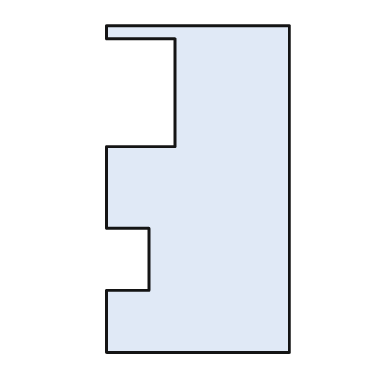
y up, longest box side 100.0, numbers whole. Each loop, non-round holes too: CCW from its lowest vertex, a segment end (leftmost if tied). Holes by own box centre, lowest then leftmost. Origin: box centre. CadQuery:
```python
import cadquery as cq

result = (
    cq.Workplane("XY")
    .moveTo(-28.0, -50.0)
    .lineTo(28.0, -50.0)
    .lineTo(28.0, 50.0)
    .lineTo(-28.0, 50.0)
    .lineTo(-28.0, 46.0)
    .lineTo(-7.0, 46.0)
    .lineTo(-7.0, 13.0)
    .lineTo(-28.0, 13.0)
    .lineTo(-28.0, -12.0)
    .lineTo(-15.0, -12.0)
    .lineTo(-15.0, -31.0)
    .lineTo(-28.0, -31.0)
    .close()
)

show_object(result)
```